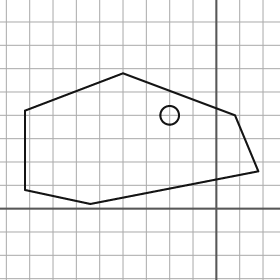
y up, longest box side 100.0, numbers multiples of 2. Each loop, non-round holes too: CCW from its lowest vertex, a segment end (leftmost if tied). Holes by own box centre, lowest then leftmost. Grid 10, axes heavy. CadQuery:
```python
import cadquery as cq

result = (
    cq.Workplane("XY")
    .moveTo(-54.0, 2.0)
    .lineTo(18.0, 16.0)
    .lineTo(8.0, 40.0)
    .lineTo(-40.0, 58.0)
    .lineTo(-82.0, 42.0)
    .lineTo(-82.0, 8.0)
    .close()
    .moveTo(-20.0, 40.0)
    .circle(4.0)
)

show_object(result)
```